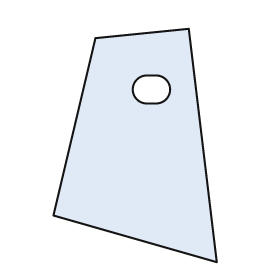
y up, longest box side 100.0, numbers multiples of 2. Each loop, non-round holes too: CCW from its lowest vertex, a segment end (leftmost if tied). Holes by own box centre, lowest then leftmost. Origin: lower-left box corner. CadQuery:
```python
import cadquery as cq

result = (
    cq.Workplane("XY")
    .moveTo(70.0, 0.0)
    .lineTo(58.0, 100.0)
    .lineTo(18.0, 96.0)
    .lineTo(0.0, 20.0)
    .close()
    .moveTo(40.0, 68.0)
    .lineTo(44.0, 68.0)
    .threePointArc((50.0, 74.0), (44.0, 80.0))
    .lineTo(40.0, 80.0)
    .threePointArc((34.0, 74.0), (40.0, 68.0))
    .close()
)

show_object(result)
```